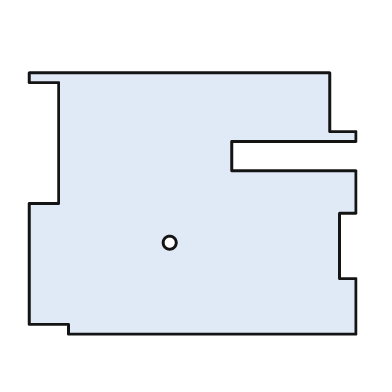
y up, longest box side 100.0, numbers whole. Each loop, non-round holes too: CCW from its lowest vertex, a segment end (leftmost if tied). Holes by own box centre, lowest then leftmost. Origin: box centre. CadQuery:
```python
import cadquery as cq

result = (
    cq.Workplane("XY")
    .moveTo(-38.0, -40.0)
    .lineTo(50.0, -40.0)
    .lineTo(50.0, -23.0)
    .lineTo(45.0, -23.0)
    .lineTo(45.0, -3.0)
    .lineTo(50.0, -3.0)
    .lineTo(50.0, 10.0)
    .lineTo(12.0, 10.0)
    .lineTo(12.0, 19.0)
    .lineTo(50.0, 19.0)
    .lineTo(50.0, 22.0)
    .lineTo(42.0, 22.0)
    .lineTo(42.0, 40.0)
    .lineTo(-50.0, 40.0)
    .lineTo(-50.0, 37.0)
    .lineTo(-41.0, 37.0)
    .lineTo(-41.0, 0.0)
    .lineTo(-50.0, 0.0)
    .lineTo(-50.0, -37.0)
    .lineTo(-38.0, -37.0)
    .close()
    .moveTo(-7.0, -12.0)
    .circle(2.0)
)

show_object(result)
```